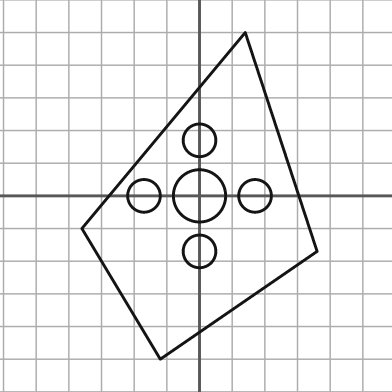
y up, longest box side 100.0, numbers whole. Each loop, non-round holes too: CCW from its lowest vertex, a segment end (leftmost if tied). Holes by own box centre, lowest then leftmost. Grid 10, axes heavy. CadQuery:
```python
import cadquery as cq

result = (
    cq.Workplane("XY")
    .moveTo(-12.0, -50.0)
    .lineTo(36.0, -17.0)
    .lineTo(14.0, 50.0)
    .lineTo(-36.0, -10.0)
    .close()
    .moveTo(0.0, -17.0)
    .circle(5.0)
    .moveTo(-17.0, 0.0)
    .circle(5.0)
    .moveTo(0.0, 0.0)
    .circle(8.0)
    .moveTo(17.0, 0.0)
    .circle(5.0)
    .moveTo(0.0, 17.0)
    .circle(5.0)
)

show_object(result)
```